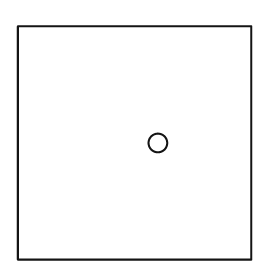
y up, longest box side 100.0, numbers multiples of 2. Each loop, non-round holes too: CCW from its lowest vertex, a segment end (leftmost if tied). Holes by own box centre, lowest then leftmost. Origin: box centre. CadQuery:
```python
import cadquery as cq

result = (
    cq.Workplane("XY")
    .moveTo(-50.0, -50.0)
    .lineTo(50.0, -50.0)
    .lineTo(50.0, 50.0)
    .lineTo(-50.0, 50.0)
    .close()
    .moveTo(10.0, 0.0)
    .circle(4.0)
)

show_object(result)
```